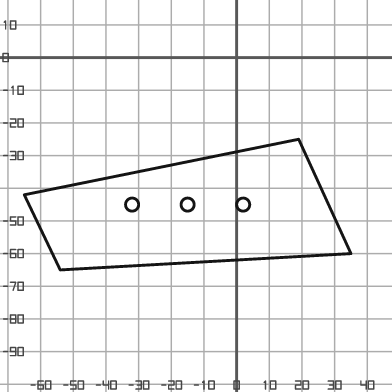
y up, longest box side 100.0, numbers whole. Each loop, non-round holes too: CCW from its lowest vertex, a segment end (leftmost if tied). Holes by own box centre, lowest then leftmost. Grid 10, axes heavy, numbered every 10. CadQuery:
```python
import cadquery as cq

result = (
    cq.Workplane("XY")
    .moveTo(-54.0, -65.0)
    .lineTo(35.0, -60.0)
    .lineTo(19.0, -25.0)
    .lineTo(-65.0, -42.0)
    .close()
    .moveTo(-32.0, -45.0)
    .circle(2.0)
    .moveTo(-15.0, -45.0)
    .circle(2.0)
    .moveTo(2.0, -45.0)
    .circle(2.0)
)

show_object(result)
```